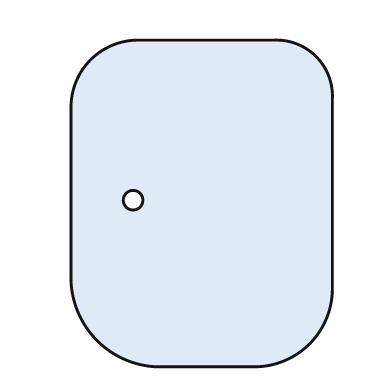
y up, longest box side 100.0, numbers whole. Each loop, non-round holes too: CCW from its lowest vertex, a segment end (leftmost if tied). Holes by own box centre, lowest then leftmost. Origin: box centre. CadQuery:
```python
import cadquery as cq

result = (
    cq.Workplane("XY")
    .moveTo(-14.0, -50.0)
    .lineTo(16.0, -50.0)
    .threePointArc((33.0, -43.0), (40.0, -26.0))
    .lineTo(40.0, 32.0)
    .threePointArc((35.0, 45.0), (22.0, 50.0))
    .lineTo(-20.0, 50.0)
    .threePointArc((-34.0, 44.0), (-40.0, 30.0))
    .lineTo(-40.0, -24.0)
    .threePointArc((-32.0, -42.0), (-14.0, -50.0))
    .close()
    .moveTo(-21.0, 1.0)
    .circle(3.0)
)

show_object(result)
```